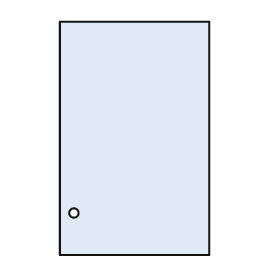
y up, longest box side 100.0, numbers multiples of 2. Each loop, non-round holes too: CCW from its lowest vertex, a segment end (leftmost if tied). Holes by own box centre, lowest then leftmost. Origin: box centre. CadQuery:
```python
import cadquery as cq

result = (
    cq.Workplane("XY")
    .moveTo(-32.0, -50.0)
    .lineTo(32.0, -50.0)
    .lineTo(32.0, 50.0)
    .lineTo(-32.0, 50.0)
    .close()
    .moveTo(-26.0, -32.0)
    .circle(2.0)
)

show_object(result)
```